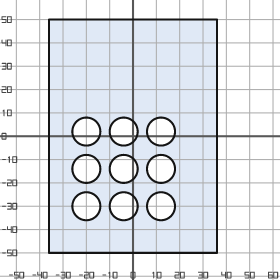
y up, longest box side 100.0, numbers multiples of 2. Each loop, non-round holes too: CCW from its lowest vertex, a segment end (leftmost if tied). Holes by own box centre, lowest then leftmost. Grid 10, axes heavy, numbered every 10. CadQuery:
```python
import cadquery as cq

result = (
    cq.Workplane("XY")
    .moveTo(-36.0, -50.0)
    .lineTo(36.0, -50.0)
    .lineTo(36.0, 50.0)
    .lineTo(-36.0, 50.0)
    .close()
    .moveTo(-20.0, -30.0)
    .circle(6.0)
    .moveTo(-4.0, -30.0)
    .circle(6.0)
    .moveTo(12.0, -30.0)
    .circle(6.0)
    .moveTo(-20.0, -14.0)
    .circle(6.0)
    .moveTo(-4.0, -14.0)
    .circle(6.0)
    .moveTo(12.0, -14.0)
    .circle(6.0)
    .moveTo(-20.0, 2.0)
    .circle(6.0)
    .moveTo(-4.0, 2.0)
    .circle(6.0)
    .moveTo(12.0, 2.0)
    .circle(6.0)
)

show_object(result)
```